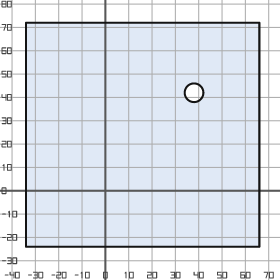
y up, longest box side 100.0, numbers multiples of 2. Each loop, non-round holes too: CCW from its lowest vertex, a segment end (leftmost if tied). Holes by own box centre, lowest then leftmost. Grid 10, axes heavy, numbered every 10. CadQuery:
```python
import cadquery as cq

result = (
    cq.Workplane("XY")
    .moveTo(-34.0, -24.0)
    .lineTo(66.0, -24.0)
    .lineTo(66.0, 72.0)
    .lineTo(-34.0, 72.0)
    .close()
    .moveTo(38.0, 42.0)
    .circle(4.0)
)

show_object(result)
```